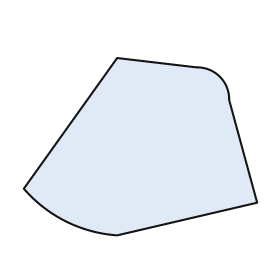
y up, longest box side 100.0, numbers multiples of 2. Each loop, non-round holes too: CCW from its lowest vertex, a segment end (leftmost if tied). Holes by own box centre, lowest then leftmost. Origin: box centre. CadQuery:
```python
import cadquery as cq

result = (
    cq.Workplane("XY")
    .moveTo(-10.0, -38.0)
    .lineTo(50.0, -24.0)
    .lineTo(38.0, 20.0)
    .threePointArc((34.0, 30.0), (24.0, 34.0))
    .lineTo(-10.0, 38.0)
    .lineTo(-50.0, -18.0)
    .threePointArc((-32.0, -32.0), (-10.0, -38.0))
    .close()
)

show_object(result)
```